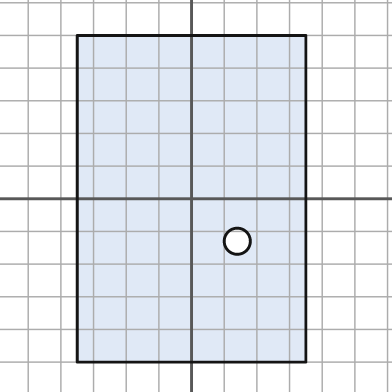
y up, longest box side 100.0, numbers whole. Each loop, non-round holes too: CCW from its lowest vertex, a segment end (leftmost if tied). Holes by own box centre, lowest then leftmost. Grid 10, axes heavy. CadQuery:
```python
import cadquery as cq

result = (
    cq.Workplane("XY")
    .moveTo(-35.0, -50.0)
    .lineTo(35.0, -50.0)
    .lineTo(35.0, 50.0)
    .lineTo(-35.0, 50.0)
    .close()
    .moveTo(14.0, -13.0)
    .circle(4.0)
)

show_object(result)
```